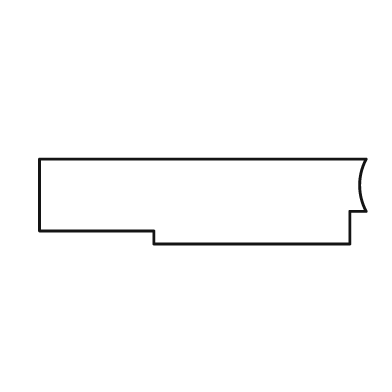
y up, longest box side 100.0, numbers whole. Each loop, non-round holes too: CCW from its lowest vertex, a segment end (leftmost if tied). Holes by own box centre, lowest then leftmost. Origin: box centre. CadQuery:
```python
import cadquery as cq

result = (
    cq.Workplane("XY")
    .moveTo(-15.0, -13.0)
    .lineTo(45.0, -13.0)
    .lineTo(45.0, -3.0)
    .lineTo(50.0, -3.0)
    .threePointArc((48.0, 5.0), (50.0, 13.0))
    .lineTo(-50.0, 13.0)
    .lineTo(-50.0, -9.0)
    .lineTo(-15.0, -9.0)
    .close()
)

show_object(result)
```